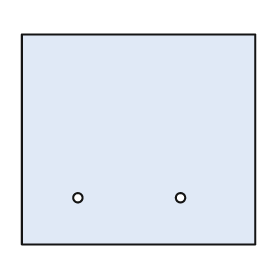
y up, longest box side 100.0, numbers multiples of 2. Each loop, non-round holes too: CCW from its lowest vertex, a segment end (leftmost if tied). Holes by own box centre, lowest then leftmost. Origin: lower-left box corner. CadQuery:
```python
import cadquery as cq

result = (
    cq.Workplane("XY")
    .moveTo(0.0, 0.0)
    .lineTo(100.0, 0.0)
    .lineTo(100.0, 90.0)
    .lineTo(0.0, 90.0)
    .close()
    .moveTo(24.0, 20.0)
    .circle(2.0)
    .moveTo(68.0, 20.0)
    .circle(2.0)
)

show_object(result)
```